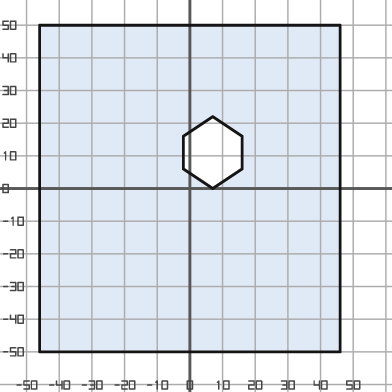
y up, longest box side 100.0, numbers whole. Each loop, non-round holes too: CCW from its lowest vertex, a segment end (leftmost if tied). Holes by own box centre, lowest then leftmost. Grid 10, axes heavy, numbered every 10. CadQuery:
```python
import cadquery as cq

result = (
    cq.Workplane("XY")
    .moveTo(-46.0, -50.0)
    .lineTo(46.0, -50.0)
    .lineTo(46.0, 50.0)
    .lineTo(-46.0, 50.0)
    .close()
    .moveTo(7.0, 0.0)
    .lineTo(16.0, 6.0)
    .lineTo(16.0, 16.0)
    .lineTo(7.0, 22.0)
    .lineTo(-2.0, 16.0)
    .lineTo(-2.0, 6.0)
    .close()
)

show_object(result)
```